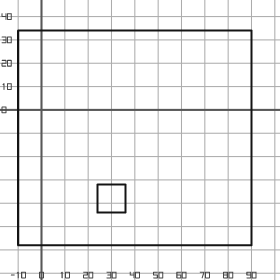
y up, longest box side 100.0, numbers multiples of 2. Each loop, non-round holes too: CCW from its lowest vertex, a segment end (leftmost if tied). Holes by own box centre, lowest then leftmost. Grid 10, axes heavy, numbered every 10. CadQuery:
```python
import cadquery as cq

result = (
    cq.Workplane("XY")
    .moveTo(-10.0, -58.0)
    .lineTo(90.0, -58.0)
    .lineTo(90.0, 34.0)
    .lineTo(-10.0, 34.0)
    .close()
    .moveTo(24.0, -44.0)
    .lineTo(36.0, -44.0)
    .lineTo(36.0, -32.0)
    .lineTo(24.0, -32.0)
    .close()
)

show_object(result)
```